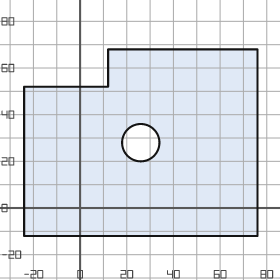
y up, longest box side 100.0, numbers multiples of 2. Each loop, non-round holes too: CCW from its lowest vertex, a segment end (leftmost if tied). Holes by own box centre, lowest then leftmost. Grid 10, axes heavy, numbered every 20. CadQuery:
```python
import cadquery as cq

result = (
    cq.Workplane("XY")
    .moveTo(-24.0, -12.0)
    .lineTo(76.0, -12.0)
    .lineTo(76.0, 68.0)
    .lineTo(12.0, 68.0)
    .lineTo(12.0, 52.0)
    .lineTo(-24.0, 52.0)
    .close()
    .moveTo(26.0, 28.0)
    .circle(8.0)
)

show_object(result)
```